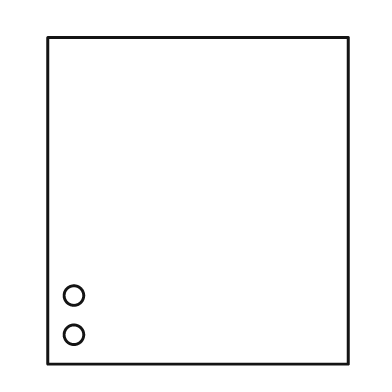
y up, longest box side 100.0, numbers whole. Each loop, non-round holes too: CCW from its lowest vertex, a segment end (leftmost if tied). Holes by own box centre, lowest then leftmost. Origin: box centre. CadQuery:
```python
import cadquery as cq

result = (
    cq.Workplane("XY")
    .moveTo(-46.0, -50.0)
    .lineTo(46.0, -50.0)
    .lineTo(46.0, 50.0)
    .lineTo(-46.0, 50.0)
    .close()
    .moveTo(-38.0, -41.0)
    .circle(3.0)
    .moveTo(-38.0, -29.0)
    .circle(3.0)
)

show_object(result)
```